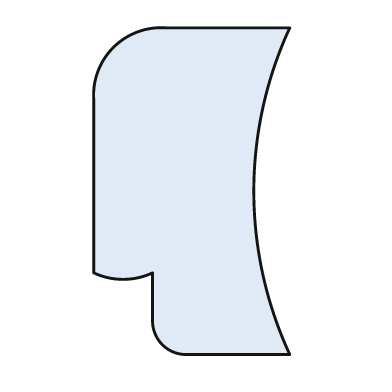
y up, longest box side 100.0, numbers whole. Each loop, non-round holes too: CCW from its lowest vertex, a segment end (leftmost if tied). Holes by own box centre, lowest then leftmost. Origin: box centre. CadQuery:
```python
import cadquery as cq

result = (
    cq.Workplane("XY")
    .moveTo(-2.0, -50.0)
    .lineTo(30.0, -50.0)
    .threePointArc((19.0, 0.0), (30.0, 50.0))
    .lineTo(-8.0, 50.0)
    .threePointArc((-24.0, 44.0), (-30.0, 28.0))
    .lineTo(-30.0, -25.0)
    .threePointArc((-21.0, -27.0), (-12.0, -25.0))
    .lineTo(-12.0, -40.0)
    .threePointArc((-9.0, -47.0), (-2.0, -50.0))
    .close()
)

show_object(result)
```